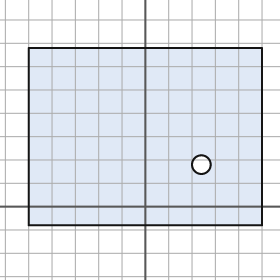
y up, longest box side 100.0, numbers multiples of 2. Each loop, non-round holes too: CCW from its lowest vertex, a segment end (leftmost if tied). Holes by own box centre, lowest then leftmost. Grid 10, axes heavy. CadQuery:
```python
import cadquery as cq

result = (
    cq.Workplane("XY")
    .moveTo(-50.0, -8.0)
    .lineTo(50.0, -8.0)
    .lineTo(50.0, 68.0)
    .lineTo(-50.0, 68.0)
    .close()
    .moveTo(24.0, 18.0)
    .circle(4.0)
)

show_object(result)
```